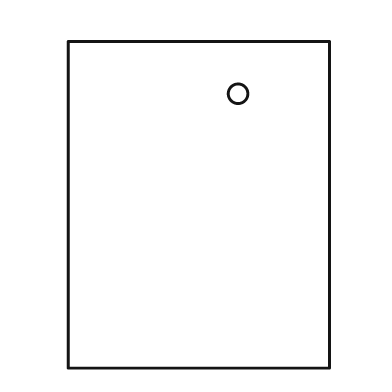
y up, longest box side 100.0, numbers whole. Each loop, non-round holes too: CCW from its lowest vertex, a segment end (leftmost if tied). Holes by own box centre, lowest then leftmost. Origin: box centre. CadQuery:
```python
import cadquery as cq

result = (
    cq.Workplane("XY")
    .moveTo(-40.0, -50.0)
    .lineTo(40.0, -50.0)
    .lineTo(40.0, 50.0)
    .lineTo(-40.0, 50.0)
    .close()
    .moveTo(12.0, 34.0)
    .circle(3.0)
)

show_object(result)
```